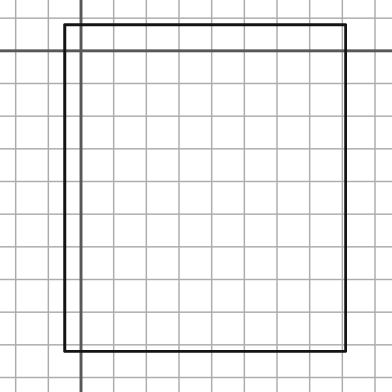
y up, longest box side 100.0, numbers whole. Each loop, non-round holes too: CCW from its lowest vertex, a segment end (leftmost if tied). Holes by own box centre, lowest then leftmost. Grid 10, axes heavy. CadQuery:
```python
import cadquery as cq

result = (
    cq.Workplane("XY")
    .moveTo(-5.0, -92.0)
    .lineTo(81.0, -92.0)
    .lineTo(81.0, 8.0)
    .lineTo(-5.0, 8.0)
    .close()
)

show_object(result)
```